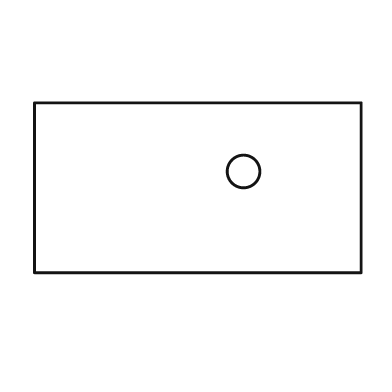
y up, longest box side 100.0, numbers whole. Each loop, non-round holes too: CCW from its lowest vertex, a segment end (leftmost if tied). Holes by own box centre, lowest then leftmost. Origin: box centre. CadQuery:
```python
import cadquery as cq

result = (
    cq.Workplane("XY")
    .moveTo(-50.0, -26.0)
    .lineTo(50.0, -26.0)
    .lineTo(50.0, 26.0)
    .lineTo(-50.0, 26.0)
    .close()
    .moveTo(14.0, 5.0)
    .circle(5.0)
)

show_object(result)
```